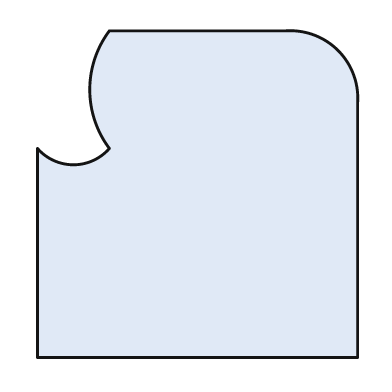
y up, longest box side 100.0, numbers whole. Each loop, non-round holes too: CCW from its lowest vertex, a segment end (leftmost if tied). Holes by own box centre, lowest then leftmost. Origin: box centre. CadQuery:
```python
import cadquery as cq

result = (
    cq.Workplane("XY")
    .moveTo(-49.0, -50.0)
    .lineTo(49.0, -50.0)
    .lineTo(49.0, 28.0)
    .threePointArc((43.0, 44.0), (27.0, 50.0))
    .lineTo(-27.0, 50.0)
    .threePointArc((-33.0, 32.0), (-27.0, 14.0))
    .threePointArc((-38.0, 9.0), (-49.0, 14.0))
    .close()
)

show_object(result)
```